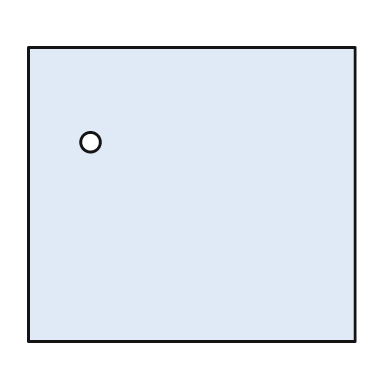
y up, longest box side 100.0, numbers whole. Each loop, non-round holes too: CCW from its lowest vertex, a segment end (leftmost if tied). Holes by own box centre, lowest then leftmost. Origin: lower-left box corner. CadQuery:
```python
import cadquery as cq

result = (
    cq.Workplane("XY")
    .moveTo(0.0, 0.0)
    .lineTo(100.0, 0.0)
    .lineTo(100.0, 90.0)
    .lineTo(0.0, 90.0)
    .close()
    .moveTo(19.0, 61.0)
    .circle(3.0)
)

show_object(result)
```